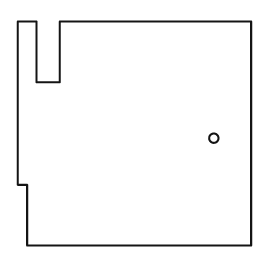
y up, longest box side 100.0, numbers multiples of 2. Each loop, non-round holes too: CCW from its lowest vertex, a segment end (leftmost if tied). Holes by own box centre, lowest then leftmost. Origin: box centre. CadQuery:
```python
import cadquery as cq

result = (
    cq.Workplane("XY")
    .moveTo(-46.0, -48.0)
    .lineTo(50.0, -48.0)
    .lineTo(50.0, 48.0)
    .lineTo(-32.0, 48.0)
    .lineTo(-32.0, 22.0)
    .lineTo(-42.0, 22.0)
    .lineTo(-42.0, 48.0)
    .lineTo(-50.0, 48.0)
    .lineTo(-50.0, -22.0)
    .lineTo(-46.0, -22.0)
    .close()
    .moveTo(34.0, -2.0)
    .circle(2.0)
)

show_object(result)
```